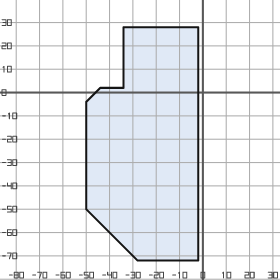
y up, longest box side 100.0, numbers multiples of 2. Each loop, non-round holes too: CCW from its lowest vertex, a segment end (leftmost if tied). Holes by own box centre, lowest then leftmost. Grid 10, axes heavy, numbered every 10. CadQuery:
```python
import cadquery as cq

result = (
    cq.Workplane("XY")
    .moveTo(-28.0, -72.0)
    .lineTo(-2.0, -72.0)
    .lineTo(-2.0, 28.0)
    .lineTo(-34.0, 28.0)
    .lineTo(-34.0, 2.0)
    .lineTo(-44.0, 2.0)
    .lineTo(-50.0, -4.0)
    .lineTo(-50.0, -50.0)
    .close()
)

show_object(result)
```